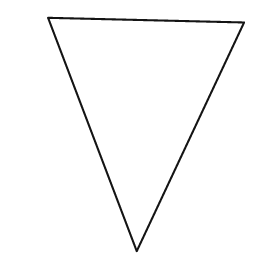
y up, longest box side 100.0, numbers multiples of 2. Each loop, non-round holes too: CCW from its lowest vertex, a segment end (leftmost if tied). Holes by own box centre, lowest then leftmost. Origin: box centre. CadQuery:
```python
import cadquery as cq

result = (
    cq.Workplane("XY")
    .moveTo(-4.0, -50.0)
    .lineTo(42.0, 48.0)
    .lineTo(-42.0, 50.0)
    .close()
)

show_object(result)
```